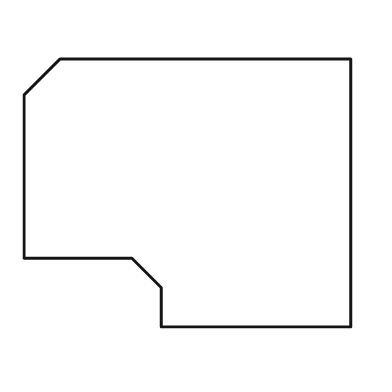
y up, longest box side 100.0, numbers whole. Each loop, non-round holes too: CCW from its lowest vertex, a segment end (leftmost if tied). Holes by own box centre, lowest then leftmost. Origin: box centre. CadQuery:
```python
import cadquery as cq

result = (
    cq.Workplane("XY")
    .moveTo(-8.0, -41.0)
    .lineTo(50.0, -41.0)
    .lineTo(50.0, 41.0)
    .lineTo(-39.0, 41.0)
    .lineTo(-50.0, 30.0)
    .lineTo(-50.0, -20.0)
    .lineTo(-17.0, -20.0)
    .lineTo(-8.0, -29.0)
    .close()
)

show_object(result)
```